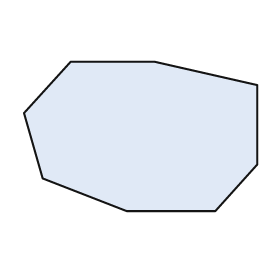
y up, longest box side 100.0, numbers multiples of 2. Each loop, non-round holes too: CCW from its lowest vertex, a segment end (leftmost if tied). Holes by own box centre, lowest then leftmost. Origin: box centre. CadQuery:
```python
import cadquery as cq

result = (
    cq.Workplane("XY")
    .moveTo(-6.0, -32.0)
    .lineTo(32.0, -32.0)
    .lineTo(50.0, -12.0)
    .lineTo(50.0, 22.0)
    .lineTo(6.0, 32.0)
    .lineTo(-30.0, 32.0)
    .lineTo(-50.0, 10.0)
    .lineTo(-42.0, -18.0)
    .close()
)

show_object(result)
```